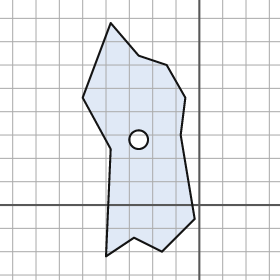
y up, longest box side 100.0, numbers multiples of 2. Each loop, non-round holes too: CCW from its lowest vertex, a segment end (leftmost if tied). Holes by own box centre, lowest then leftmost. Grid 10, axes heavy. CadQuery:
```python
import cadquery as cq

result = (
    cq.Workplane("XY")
    .moveTo(-40.0, -22.0)
    .lineTo(-28.0, -14.0)
    .lineTo(-16.0, -20.0)
    .lineTo(-2.0, -6.0)
    .lineTo(-8.0, 30.0)
    .lineTo(-6.0, 46.0)
    .lineTo(-14.0, 60.0)
    .lineTo(-26.0, 64.0)
    .lineTo(-38.0, 78.0)
    .lineTo(-50.0, 46.0)
    .lineTo(-38.0, 24.0)
    .close()
    .moveTo(-26.0, 28.0)
    .circle(4.0)
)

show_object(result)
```